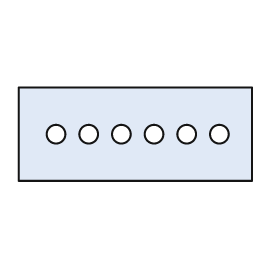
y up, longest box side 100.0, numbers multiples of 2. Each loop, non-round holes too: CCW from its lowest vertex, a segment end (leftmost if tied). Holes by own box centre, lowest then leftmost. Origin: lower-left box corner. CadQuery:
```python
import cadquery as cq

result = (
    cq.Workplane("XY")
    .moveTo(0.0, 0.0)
    .lineTo(100.0, 0.0)
    .lineTo(100.0, 40.0)
    .lineTo(0.0, 40.0)
    .close()
    .moveTo(16.0, 20.0)
    .circle(4.0)
    .moveTo(30.0, 20.0)
    .circle(4.0)
    .moveTo(44.0, 20.0)
    .circle(4.0)
    .moveTo(58.0, 20.0)
    .circle(4.0)
    .moveTo(72.0, 20.0)
    .circle(4.0)
    .moveTo(86.0, 20.0)
    .circle(4.0)
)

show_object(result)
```